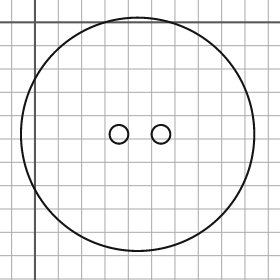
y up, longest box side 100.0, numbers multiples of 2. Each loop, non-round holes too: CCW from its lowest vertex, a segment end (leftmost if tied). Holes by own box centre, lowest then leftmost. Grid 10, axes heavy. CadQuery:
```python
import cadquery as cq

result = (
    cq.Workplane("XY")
    .moveTo(44.0, -48.0)
    .circle(50.0)
    .moveTo(36.0, -48.0)
    .circle(4.0)
    .moveTo(54.0, -48.0)
    .circle(4.0)
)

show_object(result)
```